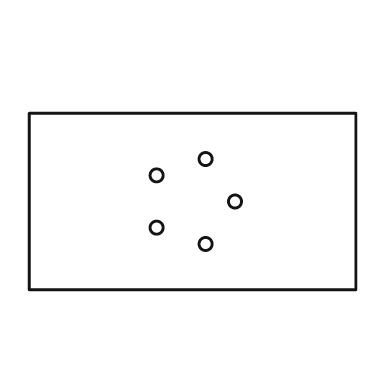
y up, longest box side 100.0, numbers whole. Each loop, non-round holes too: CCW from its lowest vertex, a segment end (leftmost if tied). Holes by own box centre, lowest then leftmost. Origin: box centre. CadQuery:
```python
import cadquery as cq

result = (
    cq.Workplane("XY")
    .moveTo(-50.0, -27.0)
    .lineTo(50.0, -27.0)
    .lineTo(50.0, 27.0)
    .lineTo(-50.0, 27.0)
    .close()
    .moveTo(4.0, -13.0)
    .circle(2.0)
    .moveTo(-11.0, -8.0)
    .circle(2.0)
    .moveTo(13.0, 0.0)
    .circle(2.0)
    .moveTo(-11.0, 8.0)
    .circle(2.0)
    .moveTo(4.0, 13.0)
    .circle(2.0)
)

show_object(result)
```